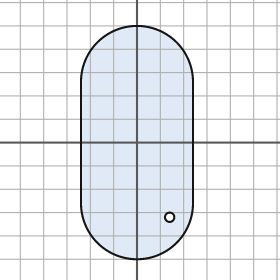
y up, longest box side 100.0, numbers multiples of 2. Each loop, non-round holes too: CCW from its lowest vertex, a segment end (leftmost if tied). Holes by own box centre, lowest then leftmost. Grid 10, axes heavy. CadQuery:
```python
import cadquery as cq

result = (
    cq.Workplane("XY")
    .moveTo(-24.0, -26.0)
    .threePointArc((0.0, -50.0), (24.0, -26.0))
    .lineTo(24.0, 26.0)
    .threePointArc((0.0, 50.0), (-24.0, 26.0))
    .close()
    .moveTo(14.0, -32.0)
    .circle(2.0)
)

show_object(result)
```